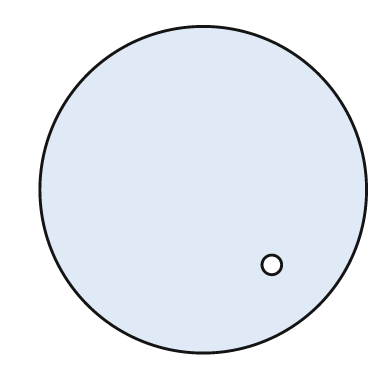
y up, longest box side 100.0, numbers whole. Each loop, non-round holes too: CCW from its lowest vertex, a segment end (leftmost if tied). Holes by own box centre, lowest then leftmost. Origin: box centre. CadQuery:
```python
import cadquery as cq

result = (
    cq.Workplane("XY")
    .moveTo(0.0, 0.0)
    .circle(50.0)
    .moveTo(21.0, -23.0)
    .circle(3.0)
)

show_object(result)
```